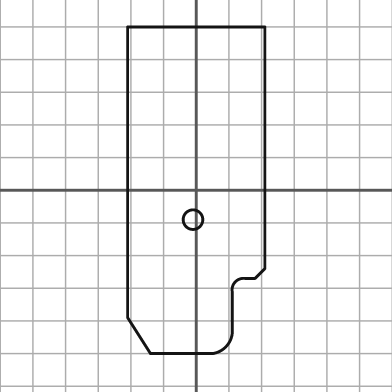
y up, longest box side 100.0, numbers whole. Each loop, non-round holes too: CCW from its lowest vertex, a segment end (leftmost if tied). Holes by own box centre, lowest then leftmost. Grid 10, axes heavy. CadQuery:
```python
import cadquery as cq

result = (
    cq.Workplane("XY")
    .moveTo(-14.0, -50.0)
    .lineTo(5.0, -50.0)
    .threePointArc((9.0, -48.0), (11.0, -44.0))
    .lineTo(11.0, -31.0)
    .threePointArc((12.0, -28.0), (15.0, -27.0))
    .lineTo(18.0, -27.0)
    .lineTo(21.0, -24.0)
    .lineTo(21.0, 50.0)
    .lineTo(-21.0, 50.0)
    .lineTo(-21.0, -39.0)
    .close()
    .moveTo(-1.0, -9.0)
    .circle(3.0)
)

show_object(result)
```